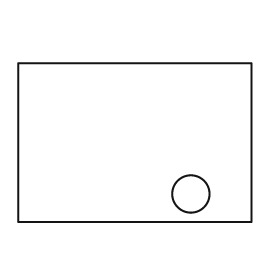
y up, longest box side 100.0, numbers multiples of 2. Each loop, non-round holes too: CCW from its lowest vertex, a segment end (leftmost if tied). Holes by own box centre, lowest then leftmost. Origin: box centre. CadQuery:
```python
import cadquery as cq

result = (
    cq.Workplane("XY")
    .moveTo(-50.0, -34.0)
    .lineTo(50.0, -34.0)
    .lineTo(50.0, 34.0)
    .lineTo(-50.0, 34.0)
    .close()
    .moveTo(24.0, -22.0)
    .circle(8.0)
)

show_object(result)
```